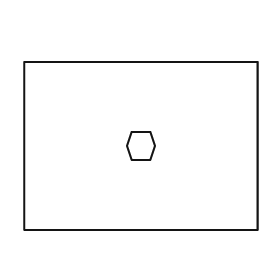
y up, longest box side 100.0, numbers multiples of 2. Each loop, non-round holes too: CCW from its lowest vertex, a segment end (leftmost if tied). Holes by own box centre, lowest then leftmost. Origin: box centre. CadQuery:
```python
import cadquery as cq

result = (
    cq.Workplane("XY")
    .moveTo(-50.0, -36.0)
    .lineTo(50.0, -36.0)
    .lineTo(50.0, 36.0)
    .lineTo(-50.0, 36.0)
    .close()
    .moveTo(-4.0, -6.0)
    .lineTo(4.0, -6.0)
    .lineTo(6.0, 0.0)
    .lineTo(4.0, 6.0)
    .lineTo(-4.0, 6.0)
    .lineTo(-6.0, 0.0)
    .close()
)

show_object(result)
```